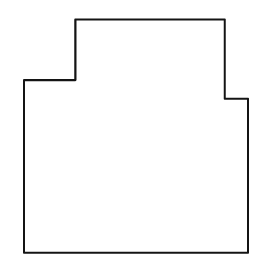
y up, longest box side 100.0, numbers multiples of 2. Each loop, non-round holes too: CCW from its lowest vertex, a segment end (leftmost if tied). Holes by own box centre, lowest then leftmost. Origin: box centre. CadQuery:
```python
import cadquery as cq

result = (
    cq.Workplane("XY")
    .moveTo(-48.0, -50.0)
    .lineTo(48.0, -50.0)
    .lineTo(48.0, 16.0)
    .lineTo(38.0, 16.0)
    .lineTo(38.0, 50.0)
    .lineTo(-26.0, 50.0)
    .lineTo(-26.0, 24.0)
    .lineTo(-48.0, 24.0)
    .close()
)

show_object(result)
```